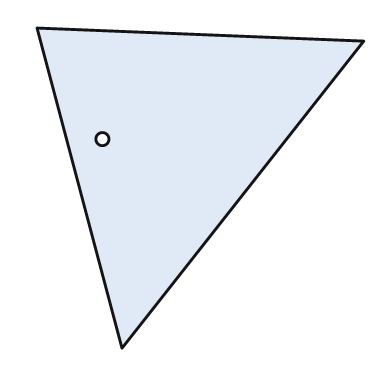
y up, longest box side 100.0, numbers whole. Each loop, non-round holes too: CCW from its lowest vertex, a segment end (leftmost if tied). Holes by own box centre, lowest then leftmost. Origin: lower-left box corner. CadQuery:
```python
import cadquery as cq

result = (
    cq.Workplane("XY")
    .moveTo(26.0, 0.0)
    .lineTo(100.0, 94.0)
    .lineTo(0.0, 98.0)
    .close()
    .moveTo(20.0, 64.0)
    .circle(2.0)
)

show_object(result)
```